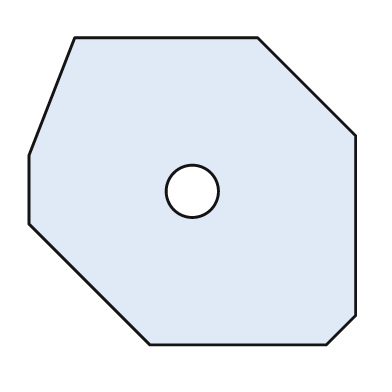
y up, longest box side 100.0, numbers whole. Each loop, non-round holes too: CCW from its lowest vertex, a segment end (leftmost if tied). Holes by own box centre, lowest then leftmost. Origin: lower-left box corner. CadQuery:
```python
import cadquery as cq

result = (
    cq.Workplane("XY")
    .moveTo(37.0, 0.0)
    .lineTo(91.0, 0.0)
    .lineTo(100.0, 9.0)
    .lineTo(100.0, 64.0)
    .lineTo(70.0, 94.0)
    .lineTo(14.0, 94.0)
    .lineTo(0.0, 58.0)
    .lineTo(0.0, 37.0)
    .close()
    .moveTo(50.0, 47.0)
    .circle(8.0)
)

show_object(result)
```